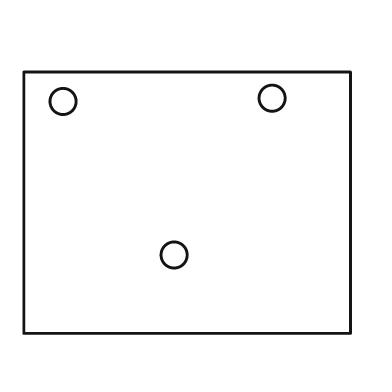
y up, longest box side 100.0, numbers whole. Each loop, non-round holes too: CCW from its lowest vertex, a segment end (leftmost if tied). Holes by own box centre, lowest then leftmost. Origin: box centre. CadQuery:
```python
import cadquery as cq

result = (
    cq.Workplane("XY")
    .moveTo(-50.0, -40.0)
    .lineTo(50.0, -40.0)
    .lineTo(50.0, 40.0)
    .lineTo(-50.0, 40.0)
    .close()
    .moveTo(-4.0, -16.0)
    .circle(4.0)
    .moveTo(-38.0, 31.0)
    .circle(4.0)
    .moveTo(26.0, 32.0)
    .circle(4.0)
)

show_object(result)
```